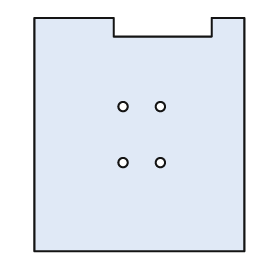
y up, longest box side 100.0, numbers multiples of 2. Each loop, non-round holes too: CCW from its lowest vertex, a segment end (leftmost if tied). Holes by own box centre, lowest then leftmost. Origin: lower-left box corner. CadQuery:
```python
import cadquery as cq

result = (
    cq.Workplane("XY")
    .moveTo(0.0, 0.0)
    .lineTo(90.0, 0.0)
    .lineTo(90.0, 100.0)
    .lineTo(76.0, 100.0)
    .lineTo(76.0, 92.0)
    .lineTo(34.0, 92.0)
    .lineTo(34.0, 100.0)
    .lineTo(0.0, 100.0)
    .close()
    .moveTo(38.0, 38.0)
    .circle(2.0)
    .moveTo(54.0, 38.0)
    .circle(2.0)
    .moveTo(38.0, 62.0)
    .circle(2.0)
    .moveTo(54.0, 62.0)
    .circle(2.0)
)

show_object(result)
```